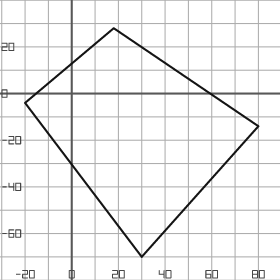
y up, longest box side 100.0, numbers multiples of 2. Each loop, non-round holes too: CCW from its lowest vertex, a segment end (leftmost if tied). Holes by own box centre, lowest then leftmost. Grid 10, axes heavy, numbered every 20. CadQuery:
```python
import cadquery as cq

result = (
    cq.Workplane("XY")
    .moveTo(30.0, -70.0)
    .lineTo(80.0, -14.0)
    .lineTo(18.0, 28.0)
    .lineTo(-20.0, -4.0)
    .close()
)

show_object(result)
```